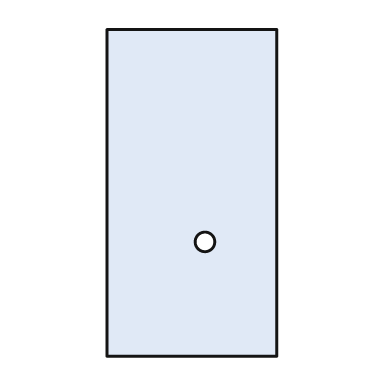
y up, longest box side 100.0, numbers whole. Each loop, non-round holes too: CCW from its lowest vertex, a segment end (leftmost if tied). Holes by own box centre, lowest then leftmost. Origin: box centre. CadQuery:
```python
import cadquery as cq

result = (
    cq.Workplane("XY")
    .moveTo(-26.0, -50.0)
    .lineTo(26.0, -50.0)
    .lineTo(26.0, 50.0)
    .lineTo(-26.0, 50.0)
    .close()
    .moveTo(4.0, -15.0)
    .circle(3.0)
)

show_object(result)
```